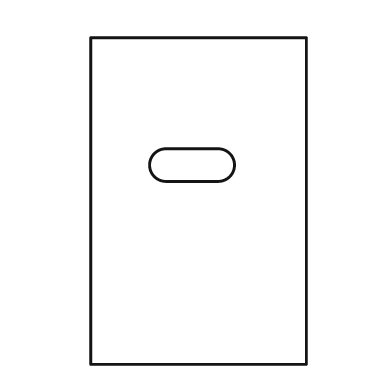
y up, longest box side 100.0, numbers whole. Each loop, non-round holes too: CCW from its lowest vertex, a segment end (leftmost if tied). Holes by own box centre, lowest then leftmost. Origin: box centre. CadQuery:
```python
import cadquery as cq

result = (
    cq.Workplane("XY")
    .moveTo(-33.0, -50.0)
    .lineTo(33.0, -50.0)
    .lineTo(33.0, 50.0)
    .lineTo(-33.0, 50.0)
    .close()
    .moveTo(-10.0, 6.0)
    .lineTo(6.0, 6.0)
    .threePointArc((11.0, 11.0), (6.0, 16.0))
    .lineTo(-10.0, 16.0)
    .threePointArc((-15.0, 11.0), (-10.0, 6.0))
    .close()
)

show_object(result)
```